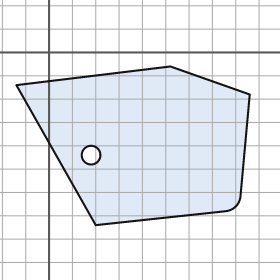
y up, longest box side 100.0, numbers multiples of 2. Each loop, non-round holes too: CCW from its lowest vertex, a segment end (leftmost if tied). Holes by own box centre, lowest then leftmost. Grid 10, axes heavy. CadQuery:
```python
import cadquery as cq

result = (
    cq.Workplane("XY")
    .moveTo(20.0, -74.0)
    .lineTo(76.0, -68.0)
    .threePointArc((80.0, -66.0), (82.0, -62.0))
    .lineTo(86.0, -18.0)
    .lineTo(52.0, -6.0)
    .lineTo(-14.0, -14.0)
    .close()
    .moveTo(18.0, -44.0)
    .circle(4.0)
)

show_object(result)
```